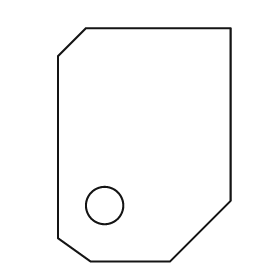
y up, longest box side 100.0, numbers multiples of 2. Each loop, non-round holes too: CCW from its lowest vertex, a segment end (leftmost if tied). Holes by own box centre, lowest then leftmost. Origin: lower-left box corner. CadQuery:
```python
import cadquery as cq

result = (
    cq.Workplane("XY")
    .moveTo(14.0, 0.0)
    .lineTo(48.0, 0.0)
    .lineTo(74.0, 26.0)
    .lineTo(74.0, 100.0)
    .lineTo(12.0, 100.0)
    .lineTo(0.0, 88.0)
    .lineTo(0.0, 10.0)
    .close()
    .moveTo(20.0, 24.0)
    .circle(8.0)
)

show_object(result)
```